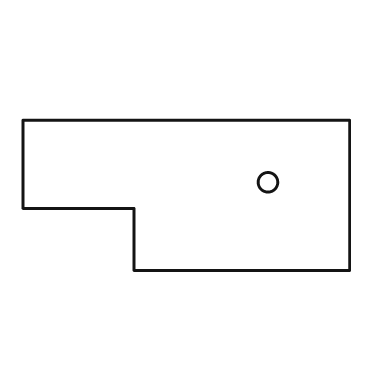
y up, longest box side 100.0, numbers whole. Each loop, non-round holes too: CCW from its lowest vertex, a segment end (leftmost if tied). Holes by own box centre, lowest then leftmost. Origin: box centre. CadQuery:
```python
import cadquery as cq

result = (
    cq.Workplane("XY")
    .moveTo(-16.0, -23.0)
    .lineTo(50.0, -23.0)
    .lineTo(50.0, 23.0)
    .lineTo(-50.0, 23.0)
    .lineTo(-50.0, -4.0)
    .lineTo(-16.0, -4.0)
    .close()
    .moveTo(25.0, 4.0)
    .circle(3.0)
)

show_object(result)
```